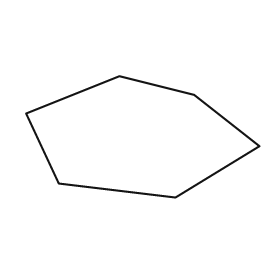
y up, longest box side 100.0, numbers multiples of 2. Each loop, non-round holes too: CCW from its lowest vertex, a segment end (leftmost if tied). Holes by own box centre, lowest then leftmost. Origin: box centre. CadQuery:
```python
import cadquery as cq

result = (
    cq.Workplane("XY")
    .moveTo(14.0, -26.0)
    .lineTo(50.0, -4.0)
    .lineTo(22.0, 18.0)
    .lineTo(-10.0, 26.0)
    .lineTo(-50.0, 10.0)
    .lineTo(-36.0, -20.0)
    .close()
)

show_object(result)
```